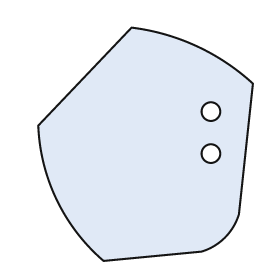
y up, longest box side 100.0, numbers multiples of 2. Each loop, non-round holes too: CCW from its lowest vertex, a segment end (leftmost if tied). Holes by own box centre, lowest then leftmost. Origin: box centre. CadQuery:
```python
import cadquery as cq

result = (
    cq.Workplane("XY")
    .moveTo(-18.0, -50.0)
    .lineTo(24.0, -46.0)
    .threePointArc((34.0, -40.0), (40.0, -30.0))
    .lineTo(46.0, 26.0)
    .threePointArc((22.0, 42.0), (-6.0, 50.0))
    .lineTo(-46.0, 8.0)
    .threePointArc((-38.0, -24.0), (-18.0, -50.0))
    .close()
    .moveTo(28.0, -4.0)
    .circle(4.0)
    .moveTo(28.0, 14.0)
    .circle(4.0)
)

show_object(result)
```